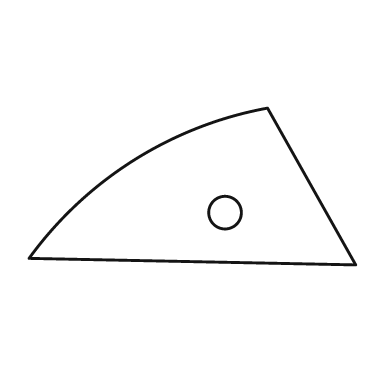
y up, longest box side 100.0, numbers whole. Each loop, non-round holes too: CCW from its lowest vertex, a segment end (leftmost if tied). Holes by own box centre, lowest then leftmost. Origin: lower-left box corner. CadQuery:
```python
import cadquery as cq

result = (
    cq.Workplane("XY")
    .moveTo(100.0, 0.0)
    .lineTo(73.0, 48.0)
    .threePointArc((32.0, 32.0), (0.0, 2.0))
    .close()
    .moveTo(60.0, 16.0)
    .circle(5.0)
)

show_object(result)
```